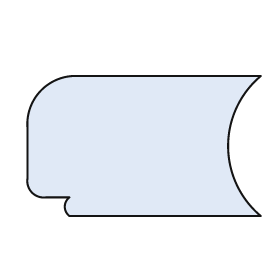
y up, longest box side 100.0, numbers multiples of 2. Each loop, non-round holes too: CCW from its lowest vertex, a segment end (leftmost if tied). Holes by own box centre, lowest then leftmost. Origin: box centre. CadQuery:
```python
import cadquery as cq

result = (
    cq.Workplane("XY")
    .moveTo(-32.0, -30.0)
    .lineTo(50.0, -30.0)
    .threePointArc((36.0, 0.0), (50.0, 30.0))
    .lineTo(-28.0, 30.0)
    .threePointArc((-44.0, 24.0), (-50.0, 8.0))
    .lineTo(-50.0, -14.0)
    .threePointArc((-48.0, -20.0), (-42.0, -22.0))
    .lineTo(-32.0, -22.0)
    .threePointArc((-34.0, -26.0), (-32.0, -30.0))
    .close()
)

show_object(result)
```